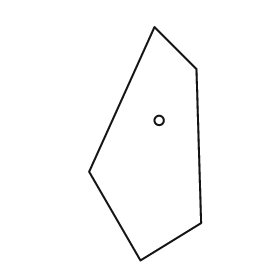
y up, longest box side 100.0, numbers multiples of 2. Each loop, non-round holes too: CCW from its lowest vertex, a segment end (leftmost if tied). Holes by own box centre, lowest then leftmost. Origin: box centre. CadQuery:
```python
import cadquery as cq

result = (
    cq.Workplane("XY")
    .moveTo(-2.0, -50.0)
    .lineTo(24.0, -34.0)
    .lineTo(22.0, 32.0)
    .lineTo(4.0, 50.0)
    .lineTo(-24.0, -12.0)
    .close()
    .moveTo(6.0, 10.0)
    .circle(2.0)
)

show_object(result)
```